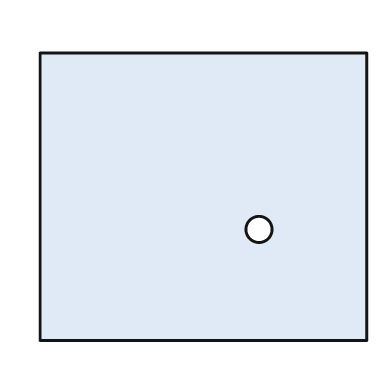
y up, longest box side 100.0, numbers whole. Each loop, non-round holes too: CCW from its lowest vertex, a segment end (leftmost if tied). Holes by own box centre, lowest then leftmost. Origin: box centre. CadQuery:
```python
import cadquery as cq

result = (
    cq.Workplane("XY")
    .moveTo(-50.0, -44.0)
    .lineTo(50.0, -44.0)
    .lineTo(50.0, 44.0)
    .lineTo(-50.0, 44.0)
    .close()
    .moveTo(17.0, -10.0)
    .circle(4.0)
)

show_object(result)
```